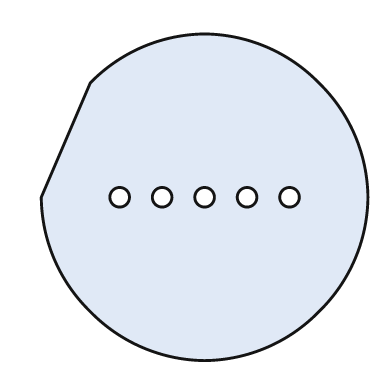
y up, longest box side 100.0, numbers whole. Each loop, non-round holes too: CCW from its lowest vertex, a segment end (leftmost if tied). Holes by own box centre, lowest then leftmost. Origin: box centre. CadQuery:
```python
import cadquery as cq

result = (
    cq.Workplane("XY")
    .moveTo(0.0, -50.0)
    .threePointArc((19.0, -46.0), (35.0, -35.0))
    .threePointArc((46.0, -19.0), (50.0, 0.0))
    .threePointArc((46.0, 19.0), (35.0, 35.0))
    .threePointArc((19.0, 46.0), (0.0, 50.0))
    .threePointArc((-19.0, 46.0), (-35.0, 35.0))
    .lineTo(-50.0, 0.0)
    .threePointArc((-46.0, -19.0), (-35.0, -35.0))
    .threePointArc((-19.0, -46.0), (0.0, -50.0))
    .close()
    .moveTo(-26.0, 0.0)
    .circle(3.0)
    .moveTo(-13.0, 0.0)
    .circle(3.0)
    .moveTo(0.0, 0.0)
    .circle(3.0)
    .moveTo(13.0, 0.0)
    .circle(3.0)
    .moveTo(26.0, 0.0)
    .circle(3.0)
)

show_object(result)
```